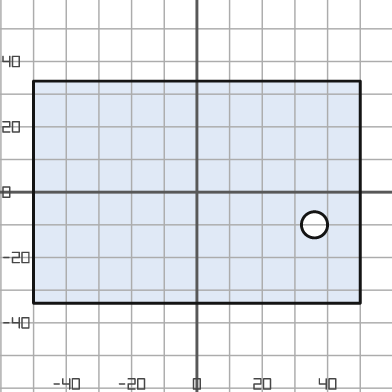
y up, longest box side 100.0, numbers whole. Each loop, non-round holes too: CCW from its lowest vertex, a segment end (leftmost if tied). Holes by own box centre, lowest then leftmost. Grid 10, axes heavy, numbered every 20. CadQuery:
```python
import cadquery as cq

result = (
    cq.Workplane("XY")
    .moveTo(-50.0, -34.0)
    .lineTo(50.0, -34.0)
    .lineTo(50.0, 34.0)
    .lineTo(-50.0, 34.0)
    .close()
    .moveTo(36.0, -10.0)
    .circle(4.0)
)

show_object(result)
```